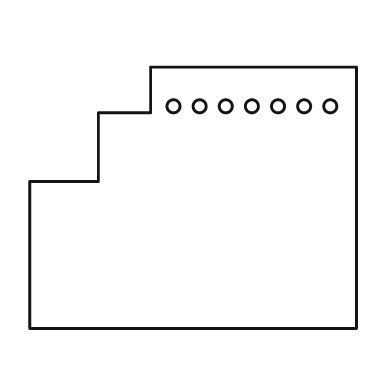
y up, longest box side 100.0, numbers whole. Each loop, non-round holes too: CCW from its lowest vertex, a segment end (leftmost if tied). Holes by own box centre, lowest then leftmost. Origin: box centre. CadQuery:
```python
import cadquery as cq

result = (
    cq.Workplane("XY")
    .moveTo(-50.0, -40.0)
    .lineTo(50.0, -40.0)
    .lineTo(50.0, 40.0)
    .lineTo(-13.0, 40.0)
    .lineTo(-13.0, 26.0)
    .lineTo(-29.0, 26.0)
    .lineTo(-29.0, 5.0)
    .lineTo(-50.0, 5.0)
    .close()
    .moveTo(-6.0, 28.0)
    .circle(2.0)
    .moveTo(2.0, 28.0)
    .circle(2.0)
    .moveTo(10.0, 28.0)
    .circle(2.0)
    .moveTo(18.0, 28.0)
    .circle(2.0)
    .moveTo(26.0, 28.0)
    .circle(2.0)
    .moveTo(34.0, 28.0)
    .circle(2.0)
    .moveTo(42.0, 28.0)
    .circle(2.0)
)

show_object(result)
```